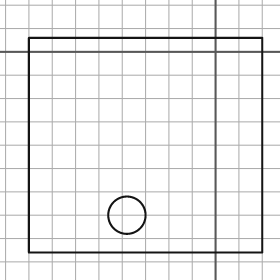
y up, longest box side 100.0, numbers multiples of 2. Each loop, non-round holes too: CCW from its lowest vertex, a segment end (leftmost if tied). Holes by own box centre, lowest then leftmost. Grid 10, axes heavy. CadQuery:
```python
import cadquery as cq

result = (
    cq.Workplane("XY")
    .moveTo(-80.0, -86.0)
    .lineTo(20.0, -86.0)
    .lineTo(20.0, 6.0)
    .lineTo(-80.0, 6.0)
    .close()
    .moveTo(-38.0, -70.0)
    .circle(8.0)
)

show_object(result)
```